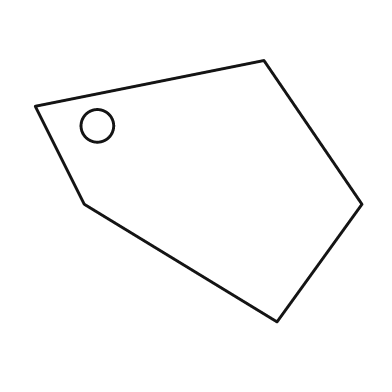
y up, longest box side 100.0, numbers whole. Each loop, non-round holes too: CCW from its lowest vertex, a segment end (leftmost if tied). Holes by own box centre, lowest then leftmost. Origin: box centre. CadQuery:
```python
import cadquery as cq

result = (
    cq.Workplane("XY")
    .moveTo(24.0, -40.0)
    .lineTo(50.0, -4.0)
    .lineTo(20.0, 40.0)
    .lineTo(-50.0, 26.0)
    .lineTo(-35.0, -4.0)
    .close()
    .moveTo(-31.0, 20.0)
    .circle(5.0)
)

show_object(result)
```